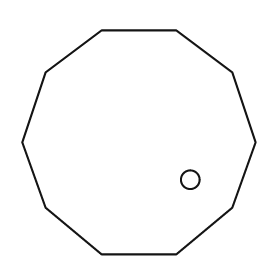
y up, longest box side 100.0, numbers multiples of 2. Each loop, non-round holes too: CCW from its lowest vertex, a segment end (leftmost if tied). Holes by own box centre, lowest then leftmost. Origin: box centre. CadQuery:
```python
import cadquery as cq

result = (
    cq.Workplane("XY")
    .moveTo(-16.0, -48.0)
    .lineTo(16.0, -48.0)
    .lineTo(40.0, -28.0)
    .lineTo(50.0, 0.0)
    .lineTo(40.0, 30.0)
    .lineTo(16.0, 48.0)
    .lineTo(-16.0, 48.0)
    .lineTo(-40.0, 30.0)
    .lineTo(-50.0, 0.0)
    .lineTo(-40.0, -28.0)
    .close()
    .moveTo(22.0, -16.0)
    .circle(4.0)
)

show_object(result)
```